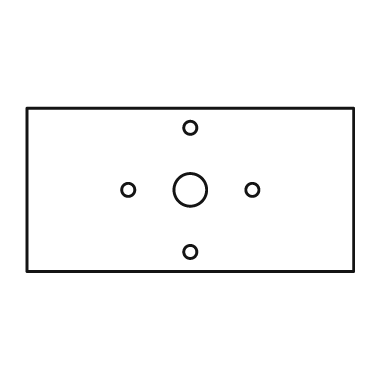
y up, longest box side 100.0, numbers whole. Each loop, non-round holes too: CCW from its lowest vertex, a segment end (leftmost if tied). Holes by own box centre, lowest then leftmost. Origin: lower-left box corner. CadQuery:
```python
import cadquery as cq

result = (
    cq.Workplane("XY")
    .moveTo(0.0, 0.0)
    .lineTo(100.0, 0.0)
    .lineTo(100.0, 50.0)
    .lineTo(0.0, 50.0)
    .close()
    .moveTo(50.0, 6.0)
    .circle(2.0)
    .moveTo(31.0, 25.0)
    .circle(2.0)
    .moveTo(50.0, 25.0)
    .circle(5.0)
    .moveTo(69.0, 25.0)
    .circle(2.0)
    .moveTo(50.0, 44.0)
    .circle(2.0)
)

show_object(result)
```